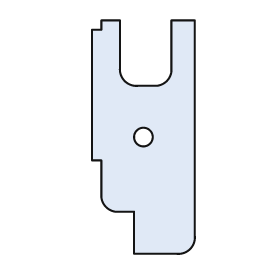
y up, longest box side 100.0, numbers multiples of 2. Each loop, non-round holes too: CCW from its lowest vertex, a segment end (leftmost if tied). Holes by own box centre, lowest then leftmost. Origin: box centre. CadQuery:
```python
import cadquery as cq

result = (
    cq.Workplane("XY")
    .moveTo(-4.0, -50.0)
    .lineTo(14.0, -50.0)
    .threePointArc((20.0, -48.0), (22.0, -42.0))
    .lineTo(22.0, 50.0)
    .lineTo(12.0, 50.0)
    .lineTo(12.0, 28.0)
    .threePointArc((10.0, 24.0), (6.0, 22.0))
    .lineTo(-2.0, 22.0)
    .threePointArc((-8.0, 24.0), (-10.0, 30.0))
    .lineTo(-10.0, 50.0)
    .lineTo(-18.0, 50.0)
    .lineTo(-18.0, 46.0)
    .lineTo(-22.0, 46.0)
    .lineTo(-22.0, -10.0)
    .lineTo(-18.0, -10.0)
    .lineTo(-18.0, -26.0)
    .threePointArc((-16.0, -30.0), (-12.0, -32.0))
    .lineTo(-4.0, -32.0)
    .close()
    .moveTo(0.0, 0.0)
    .circle(4.0)
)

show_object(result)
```